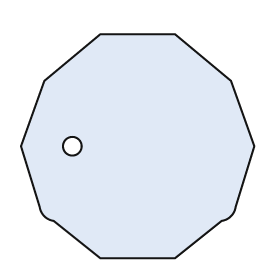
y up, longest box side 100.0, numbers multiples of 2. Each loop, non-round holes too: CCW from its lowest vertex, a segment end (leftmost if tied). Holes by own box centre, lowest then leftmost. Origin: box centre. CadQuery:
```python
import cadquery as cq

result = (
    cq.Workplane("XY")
    .moveTo(-16.0, -48.0)
    .lineTo(16.0, -48.0)
    .lineTo(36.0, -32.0)
    .threePointArc((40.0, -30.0), (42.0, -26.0))
    .lineTo(50.0, 0.0)
    .lineTo(40.0, 28.0)
    .lineTo(16.0, 48.0)
    .lineTo(-16.0, 48.0)
    .lineTo(-40.0, 28.0)
    .lineTo(-50.0, 0.0)
    .lineTo(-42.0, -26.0)
    .threePointArc((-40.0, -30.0), (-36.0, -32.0))
    .close()
    .moveTo(-28.0, 0.0)
    .circle(4.0)
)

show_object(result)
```